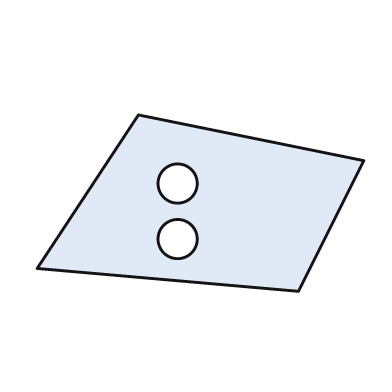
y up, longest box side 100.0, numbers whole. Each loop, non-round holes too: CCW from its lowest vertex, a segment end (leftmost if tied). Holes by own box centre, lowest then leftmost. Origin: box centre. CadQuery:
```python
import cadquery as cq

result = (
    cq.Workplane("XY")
    .moveTo(30.0, -27.0)
    .lineTo(50.0, 13.0)
    .lineTo(-19.0, 27.0)
    .lineTo(-50.0, -20.0)
    .close()
    .moveTo(-7.0, -11.0)
    .circle(6.0)
    .moveTo(-7.0, 6.0)
    .circle(6.0)
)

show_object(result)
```